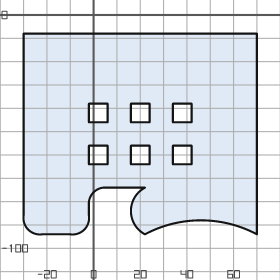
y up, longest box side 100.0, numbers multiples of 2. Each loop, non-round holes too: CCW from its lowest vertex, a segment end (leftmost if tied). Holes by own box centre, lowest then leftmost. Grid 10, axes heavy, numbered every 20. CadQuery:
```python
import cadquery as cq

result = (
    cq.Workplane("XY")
    .moveTo(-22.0, -94.0)
    .lineTo(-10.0, -94.0)
    .threePointArc((-4.0, -92.0), (-2.0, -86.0))
    .lineTo(-2.0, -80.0)
    .threePointArc((0.0, -76.0), (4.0, -74.0))
    .lineTo(22.0, -74.0)
    .threePointArc((16.0, -84.0), (22.0, -94.0))
    .threePointArc((46.0, -88.0), (70.0, -94.0))
    .lineTo(70.0, -8.0)
    .lineTo(-30.0, -8.0)
    .lineTo(-30.0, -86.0)
    .threePointArc((-28.0, -92.0), (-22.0, -94.0))
    .close()
    .moveTo(-2.0, -64.0)
    .lineTo(6.0, -64.0)
    .lineTo(6.0, -56.0)
    .lineTo(-2.0, -56.0)
    .close()
    .moveTo(16.0, -64.0)
    .lineTo(24.0, -64.0)
    .lineTo(24.0, -56.0)
    .lineTo(16.0, -56.0)
    .close()
    .moveTo(34.0, -64.0)
    .lineTo(42.0, -64.0)
    .lineTo(42.0, -56.0)
    .lineTo(34.0, -56.0)
    .close()
    .moveTo(-2.0, -46.0)
    .lineTo(6.0, -46.0)
    .lineTo(6.0, -38.0)
    .lineTo(-2.0, -38.0)
    .close()
    .moveTo(16.0, -46.0)
    .lineTo(24.0, -46.0)
    .lineTo(24.0, -38.0)
    .lineTo(16.0, -38.0)
    .close()
    .moveTo(34.0, -46.0)
    .lineTo(42.0, -46.0)
    .lineTo(42.0, -38.0)
    .lineTo(34.0, -38.0)
    .close()
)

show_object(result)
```